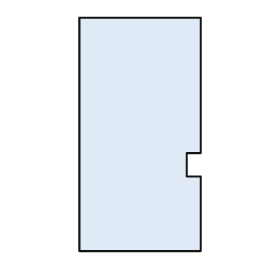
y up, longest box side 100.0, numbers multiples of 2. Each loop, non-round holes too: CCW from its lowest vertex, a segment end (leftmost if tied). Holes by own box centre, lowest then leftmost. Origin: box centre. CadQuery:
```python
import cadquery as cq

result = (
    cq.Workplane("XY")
    .moveTo(-26.0, -50.0)
    .lineTo(26.0, -50.0)
    .lineTo(26.0, -18.0)
    .lineTo(20.0, -18.0)
    .lineTo(20.0, -8.0)
    .lineTo(26.0, -8.0)
    .lineTo(26.0, 50.0)
    .lineTo(-26.0, 50.0)
    .close()
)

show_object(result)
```